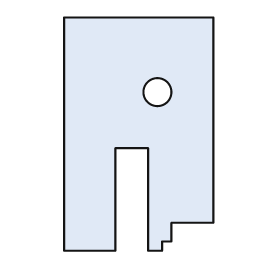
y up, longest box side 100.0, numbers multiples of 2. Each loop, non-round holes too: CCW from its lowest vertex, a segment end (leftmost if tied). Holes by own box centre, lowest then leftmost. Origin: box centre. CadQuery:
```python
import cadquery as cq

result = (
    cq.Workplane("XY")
    .moveTo(-32.0, -50.0)
    .lineTo(-10.0, -50.0)
    .lineTo(-10.0, -6.0)
    .lineTo(4.0, -6.0)
    .lineTo(4.0, -50.0)
    .lineTo(10.0, -50.0)
    .lineTo(10.0, -46.0)
    .lineTo(14.0, -46.0)
    .lineTo(14.0, -38.0)
    .lineTo(32.0, -38.0)
    .lineTo(32.0, 50.0)
    .lineTo(-32.0, 50.0)
    .close()
    .moveTo(8.0, 18.0)
    .circle(6.0)
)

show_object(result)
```